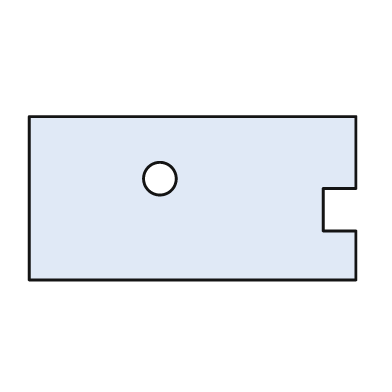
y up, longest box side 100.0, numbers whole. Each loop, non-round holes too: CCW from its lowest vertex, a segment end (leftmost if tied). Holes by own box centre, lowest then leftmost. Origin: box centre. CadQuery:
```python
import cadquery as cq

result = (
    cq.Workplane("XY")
    .moveTo(-50.0, -25.0)
    .lineTo(50.0, -25.0)
    .lineTo(50.0, -10.0)
    .lineTo(40.0, -10.0)
    .lineTo(40.0, 3.0)
    .lineTo(50.0, 3.0)
    .lineTo(50.0, 25.0)
    .lineTo(-50.0, 25.0)
    .close()
    .moveTo(-10.0, 6.0)
    .circle(5.0)
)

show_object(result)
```